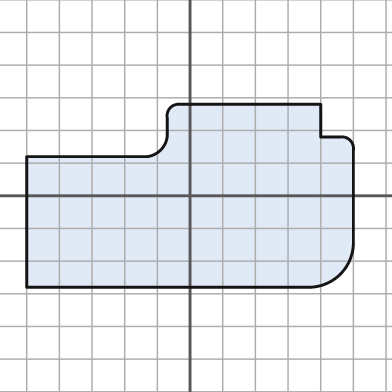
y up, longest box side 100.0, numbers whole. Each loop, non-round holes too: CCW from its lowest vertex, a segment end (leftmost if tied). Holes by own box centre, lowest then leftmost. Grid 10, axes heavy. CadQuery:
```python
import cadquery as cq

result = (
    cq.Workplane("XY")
    .moveTo(-50.0, -28.0)
    .lineTo(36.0, -28.0)
    .threePointArc((46.0, -24.0), (50.0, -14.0))
    .lineTo(50.0, 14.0)
    .threePointArc((49.0, 17.0), (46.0, 18.0))
    .lineTo(40.0, 18.0)
    .lineTo(40.0, 28.0)
    .lineTo(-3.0, 28.0)
    .threePointArc((-6.0, 27.0), (-7.0, 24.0))
    .lineTo(-7.0, 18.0)
    .threePointArc((-9.0, 14.0), (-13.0, 12.0))
    .lineTo(-50.0, 12.0)
    .close()
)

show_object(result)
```